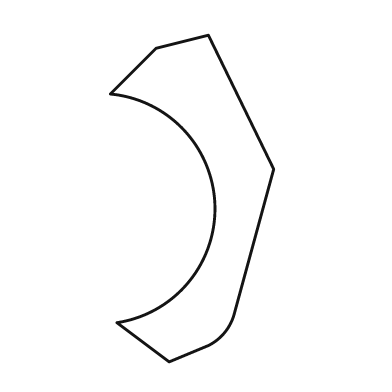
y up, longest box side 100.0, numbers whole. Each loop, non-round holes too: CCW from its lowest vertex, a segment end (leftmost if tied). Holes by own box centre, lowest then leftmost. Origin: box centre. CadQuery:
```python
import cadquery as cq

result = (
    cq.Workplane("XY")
    .moveTo(-7.0, -50.0)
    .lineTo(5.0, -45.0)
    .threePointArc((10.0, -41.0), (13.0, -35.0))
    .lineTo(25.0, 9.0)
    .lineTo(5.0, 50.0)
    .lineTo(-11.0, 46.0)
    .lineTo(-25.0, 32.0)
    .threePointArc((7.0, -2.0), (-23.0, -38.0))
    .close()
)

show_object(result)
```